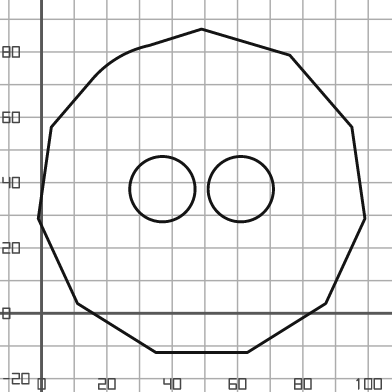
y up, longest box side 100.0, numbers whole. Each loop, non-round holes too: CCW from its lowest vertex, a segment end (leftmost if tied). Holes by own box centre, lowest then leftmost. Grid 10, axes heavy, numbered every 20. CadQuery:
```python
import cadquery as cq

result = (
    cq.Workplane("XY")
    .moveTo(35.0, -12.0)
    .lineTo(63.0, -12.0)
    .lineTo(87.0, 3.0)
    .lineTo(99.0, 29.0)
    .lineTo(95.0, 57.0)
    .lineTo(76.0, 79.0)
    .lineTo(49.0, 87.0)
    .lineTo(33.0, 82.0)
    .threePointArc((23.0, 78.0), (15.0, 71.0))
    .lineTo(3.0, 57.0)
    .lineTo(-1.0, 29.0)
    .lineTo(11.0, 3.0)
    .close()
    .moveTo(37.0, 38.0)
    .circle(10.0)
    .moveTo(61.0, 38.0)
    .circle(10.0)
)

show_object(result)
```